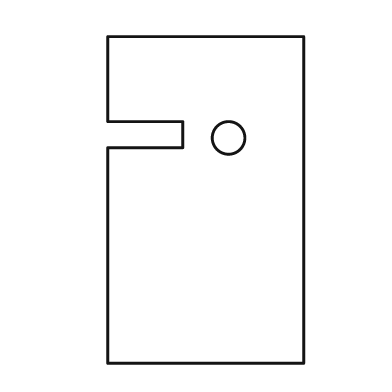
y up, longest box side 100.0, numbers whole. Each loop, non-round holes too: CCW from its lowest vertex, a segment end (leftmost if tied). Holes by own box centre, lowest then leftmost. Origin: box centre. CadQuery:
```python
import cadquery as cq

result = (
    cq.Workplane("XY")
    .moveTo(-30.0, -50.0)
    .lineTo(30.0, -50.0)
    .lineTo(30.0, 50.0)
    .lineTo(-30.0, 50.0)
    .lineTo(-30.0, 24.0)
    .lineTo(-7.0, 24.0)
    .lineTo(-7.0, 16.0)
    .lineTo(-30.0, 16.0)
    .close()
    .moveTo(7.0, 19.0)
    .circle(5.0)
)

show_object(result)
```